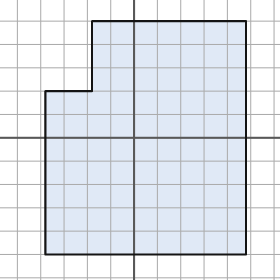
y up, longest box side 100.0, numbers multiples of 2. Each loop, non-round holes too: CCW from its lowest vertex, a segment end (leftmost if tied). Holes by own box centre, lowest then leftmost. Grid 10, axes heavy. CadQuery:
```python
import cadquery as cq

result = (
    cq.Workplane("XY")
    .moveTo(-38.0, -50.0)
    .lineTo(48.0, -50.0)
    .lineTo(48.0, 50.0)
    .lineTo(-18.0, 50.0)
    .lineTo(-18.0, 20.0)
    .lineTo(-38.0, 20.0)
    .close()
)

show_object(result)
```